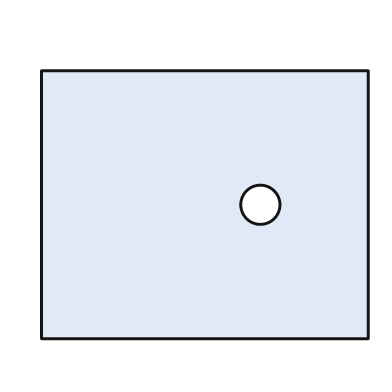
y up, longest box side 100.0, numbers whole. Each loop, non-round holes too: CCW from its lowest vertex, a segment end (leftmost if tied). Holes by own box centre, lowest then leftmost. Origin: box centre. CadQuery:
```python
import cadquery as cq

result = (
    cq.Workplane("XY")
    .moveTo(-50.0, -41.0)
    .lineTo(50.0, -41.0)
    .lineTo(50.0, 41.0)
    .lineTo(-50.0, 41.0)
    .close()
    .moveTo(17.0, 0.0)
    .circle(6.0)
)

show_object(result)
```